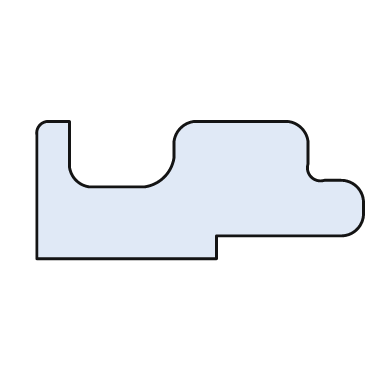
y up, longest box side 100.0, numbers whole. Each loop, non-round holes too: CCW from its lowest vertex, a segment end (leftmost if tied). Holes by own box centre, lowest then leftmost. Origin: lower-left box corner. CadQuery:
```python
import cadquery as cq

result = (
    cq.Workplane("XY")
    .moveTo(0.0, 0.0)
    .lineTo(55.0, 0.0)
    .lineTo(55.0, 7.0)
    .lineTo(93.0, 7.0)
    .threePointArc((98.0, 9.0), (100.0, 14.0))
    .lineTo(100.0, 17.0)
    .threePointArc((98.0, 22.0), (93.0, 24.0))
    .lineTo(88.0, 24.0)
    .threePointArc((84.0, 25.0), (83.0, 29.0))
    .lineTo(83.0, 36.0)
    .threePointArc((81.0, 40.0), (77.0, 42.0))
    .lineTo(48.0, 42.0)
    .threePointArc((44.0, 40.0), (42.0, 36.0))
    .lineTo(42.0, 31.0)
    .threePointArc((39.0, 25.0), (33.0, 22.0))
    .lineTo(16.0, 22.0)
    .threePointArc((12.0, 24.0), (10.0, 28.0))
    .lineTo(10.0, 42.0)
    .lineTo(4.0, 42.0)
    .threePointArc((1.0, 41.0), (0.0, 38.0))
    .close()
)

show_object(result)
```